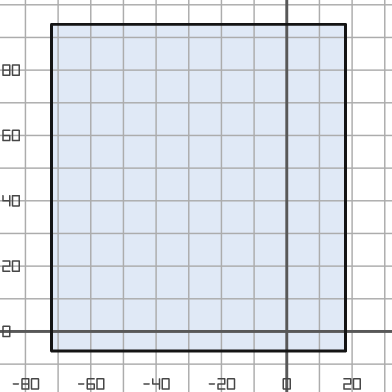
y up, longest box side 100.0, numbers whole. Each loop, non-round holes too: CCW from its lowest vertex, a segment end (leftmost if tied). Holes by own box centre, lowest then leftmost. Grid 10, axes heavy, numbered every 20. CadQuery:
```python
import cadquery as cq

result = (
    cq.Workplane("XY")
    .moveTo(-72.0, -6.0)
    .lineTo(18.0, -6.0)
    .lineTo(18.0, 94.0)
    .lineTo(-72.0, 94.0)
    .close()
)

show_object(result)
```